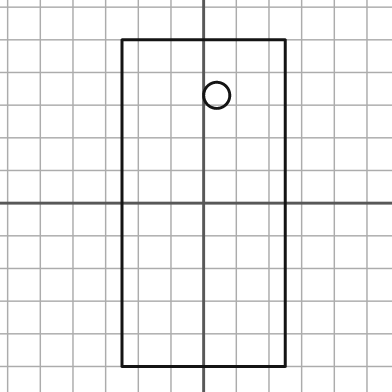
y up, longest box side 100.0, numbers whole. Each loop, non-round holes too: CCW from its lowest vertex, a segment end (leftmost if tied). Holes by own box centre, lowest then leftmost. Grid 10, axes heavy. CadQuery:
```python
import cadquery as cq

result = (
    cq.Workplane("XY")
    .moveTo(-25.0, -50.0)
    .lineTo(25.0, -50.0)
    .lineTo(25.0, 50.0)
    .lineTo(-25.0, 50.0)
    .close()
    .moveTo(4.0, 33.0)
    .circle(4.0)
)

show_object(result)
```